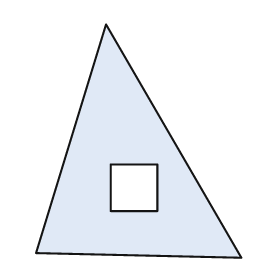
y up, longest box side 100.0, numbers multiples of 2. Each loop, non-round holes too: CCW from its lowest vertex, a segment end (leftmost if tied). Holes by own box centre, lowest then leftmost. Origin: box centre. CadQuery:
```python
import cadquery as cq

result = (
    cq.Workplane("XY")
    .moveTo(44.0, -50.0)
    .lineTo(-14.0, 50.0)
    .lineTo(-44.0, -48.0)
    .close()
    .moveTo(-12.0, -30.0)
    .lineTo(8.0, -30.0)
    .lineTo(8.0, -10.0)
    .lineTo(-12.0, -10.0)
    .close()
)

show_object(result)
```